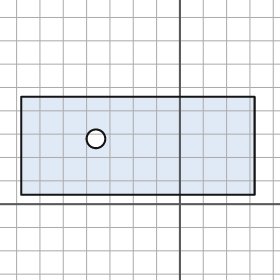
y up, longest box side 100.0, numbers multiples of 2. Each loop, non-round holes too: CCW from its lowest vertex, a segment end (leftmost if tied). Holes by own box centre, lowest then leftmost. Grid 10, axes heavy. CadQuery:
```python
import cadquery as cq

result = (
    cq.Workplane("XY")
    .moveTo(-68.0, 4.0)
    .lineTo(32.0, 4.0)
    .lineTo(32.0, 46.0)
    .lineTo(-68.0, 46.0)
    .close()
    .moveTo(-36.0, 28.0)
    .circle(4.0)
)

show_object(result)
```